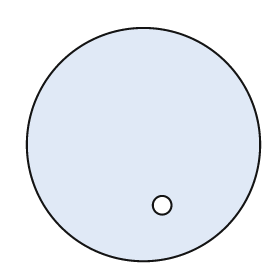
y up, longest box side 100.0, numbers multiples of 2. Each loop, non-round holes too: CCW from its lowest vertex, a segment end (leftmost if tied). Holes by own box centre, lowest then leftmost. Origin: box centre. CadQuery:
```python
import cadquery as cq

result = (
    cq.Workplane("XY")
    .moveTo(0.0, 0.0)
    .circle(50.0)
    .moveTo(8.0, -26.0)
    .circle(4.0)
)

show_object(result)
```